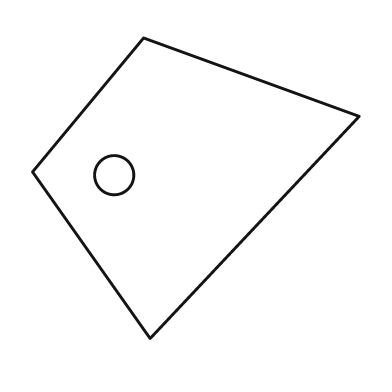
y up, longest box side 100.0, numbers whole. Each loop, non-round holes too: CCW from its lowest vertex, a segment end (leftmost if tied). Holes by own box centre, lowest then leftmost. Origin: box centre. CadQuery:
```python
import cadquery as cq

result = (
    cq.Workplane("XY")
    .moveTo(-14.0, -46.0)
    .lineTo(50.0, 22.0)
    .lineTo(-16.0, 46.0)
    .lineTo(-50.0, 5.0)
    .close()
    .moveTo(-25.0, 4.0)
    .circle(6.0)
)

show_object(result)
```